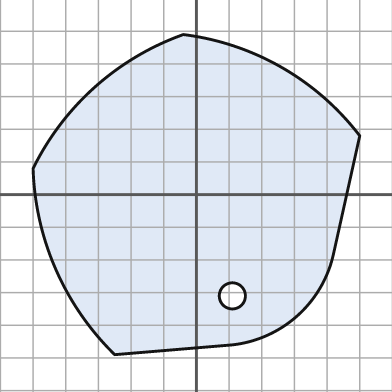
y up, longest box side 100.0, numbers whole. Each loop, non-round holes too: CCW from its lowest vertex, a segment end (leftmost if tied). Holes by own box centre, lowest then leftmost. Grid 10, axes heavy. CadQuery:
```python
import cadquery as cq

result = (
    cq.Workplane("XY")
    .moveTo(-25.0, -49.0)
    .lineTo(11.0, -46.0)
    .threePointArc((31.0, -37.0), (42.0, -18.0))
    .lineTo(50.0, 18.0)
    .threePointArc((26.0, 39.0), (-4.0, 49.0))
    .threePointArc((-31.0, 33.0), (-50.0, 8.0))
    .threePointArc((-43.0, -23.0), (-25.0, -49.0))
    .close()
    .moveTo(11.0, -31.0)
    .circle(4.0)
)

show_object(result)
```